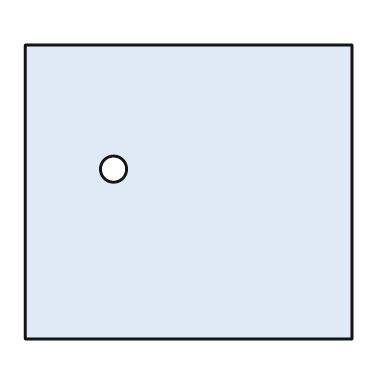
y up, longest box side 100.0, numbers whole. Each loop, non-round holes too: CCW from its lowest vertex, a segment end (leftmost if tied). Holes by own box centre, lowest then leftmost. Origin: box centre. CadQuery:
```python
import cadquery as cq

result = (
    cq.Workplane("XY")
    .moveTo(-50.0, -45.0)
    .lineTo(50.0, -45.0)
    .lineTo(50.0, 45.0)
    .lineTo(-50.0, 45.0)
    .close()
    .moveTo(-23.0, 7.0)
    .circle(4.0)
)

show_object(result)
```